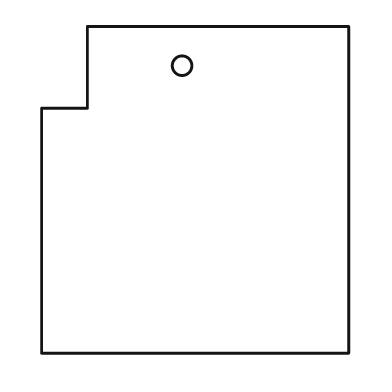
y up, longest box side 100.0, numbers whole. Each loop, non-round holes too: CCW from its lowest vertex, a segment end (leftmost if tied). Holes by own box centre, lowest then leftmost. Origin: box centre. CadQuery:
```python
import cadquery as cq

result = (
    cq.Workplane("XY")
    .moveTo(-47.0, -50.0)
    .lineTo(47.0, -50.0)
    .lineTo(47.0, 50.0)
    .lineTo(-33.0, 50.0)
    .lineTo(-33.0, 25.0)
    .lineTo(-47.0, 25.0)
    .close()
    .moveTo(-4.0, 38.0)
    .circle(3.0)
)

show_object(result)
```